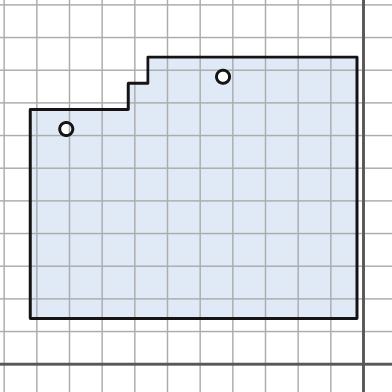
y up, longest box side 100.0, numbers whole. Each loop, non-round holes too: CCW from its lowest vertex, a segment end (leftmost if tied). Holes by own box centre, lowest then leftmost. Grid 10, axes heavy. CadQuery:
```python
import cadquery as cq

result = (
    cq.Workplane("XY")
    .moveTo(-102.0, 14.0)
    .lineTo(-2.0, 14.0)
    .lineTo(-2.0, 94.0)
    .lineTo(-66.0, 94.0)
    .lineTo(-66.0, 86.0)
    .lineTo(-72.0, 86.0)
    .lineTo(-72.0, 78.0)
    .lineTo(-102.0, 78.0)
    .close()
    .moveTo(-91.0, 72.0)
    .circle(2.0)
    .moveTo(-43.0, 88.0)
    .circle(2.0)
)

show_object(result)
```